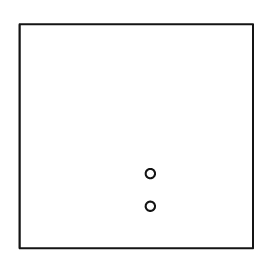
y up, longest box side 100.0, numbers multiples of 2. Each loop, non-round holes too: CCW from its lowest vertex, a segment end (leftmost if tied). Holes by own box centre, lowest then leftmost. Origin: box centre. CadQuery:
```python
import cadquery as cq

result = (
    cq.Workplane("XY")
    .moveTo(-50.0, -48.0)
    .lineTo(50.0, -48.0)
    .lineTo(50.0, 48.0)
    .lineTo(-50.0, 48.0)
    .close()
    .moveTo(6.0, -30.0)
    .circle(2.0)
    .moveTo(6.0, -16.0)
    .circle(2.0)
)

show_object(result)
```